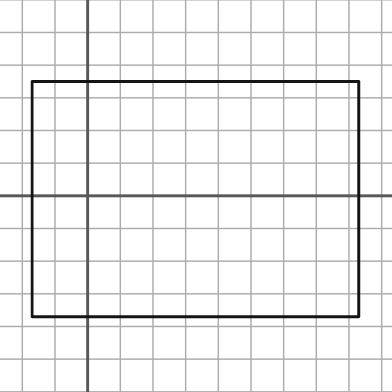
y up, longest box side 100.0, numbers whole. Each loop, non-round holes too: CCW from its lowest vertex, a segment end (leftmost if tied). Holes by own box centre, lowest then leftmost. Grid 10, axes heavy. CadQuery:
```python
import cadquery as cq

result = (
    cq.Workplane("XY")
    .moveTo(-17.0, -37.0)
    .lineTo(83.0, -37.0)
    .lineTo(83.0, 35.0)
    .lineTo(-17.0, 35.0)
    .close()
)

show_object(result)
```